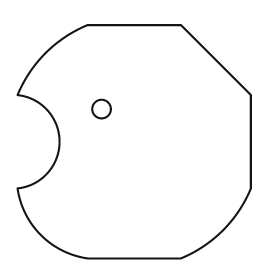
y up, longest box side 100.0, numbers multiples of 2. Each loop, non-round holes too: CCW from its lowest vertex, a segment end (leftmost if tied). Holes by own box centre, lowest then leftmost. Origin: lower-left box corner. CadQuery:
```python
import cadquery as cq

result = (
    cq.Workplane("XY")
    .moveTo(30.0, 0.0)
    .lineTo(70.0, 0.0)
    .threePointArc((88.0, 12.0), (100.0, 30.0))
    .lineTo(100.0, 70.0)
    .lineTo(70.0, 100.0)
    .lineTo(30.0, 100.0)
    .threePointArc((12.0, 88.0), (0.0, 70.0))
    .threePointArc((18.0, 50.0), (0.0, 30.0))
    .threePointArc((10.0, 10.0), (30.0, 0.0))
    .close()
    .moveTo(36.0, 64.0)
    .circle(4.0)
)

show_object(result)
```